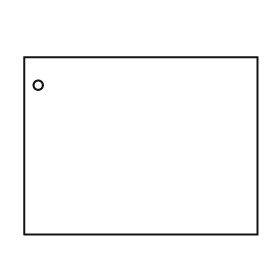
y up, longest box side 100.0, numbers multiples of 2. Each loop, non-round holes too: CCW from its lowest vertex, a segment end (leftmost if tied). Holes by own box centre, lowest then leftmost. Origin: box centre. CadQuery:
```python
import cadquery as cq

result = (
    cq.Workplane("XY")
    .moveTo(-50.0, -38.0)
    .lineTo(50.0, -38.0)
    .lineTo(50.0, 38.0)
    .lineTo(-50.0, 38.0)
    .close()
    .moveTo(-44.0, 26.0)
    .circle(2.0)
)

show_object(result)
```